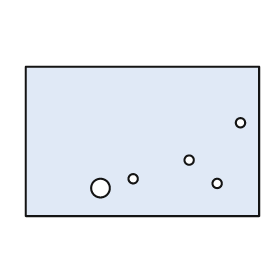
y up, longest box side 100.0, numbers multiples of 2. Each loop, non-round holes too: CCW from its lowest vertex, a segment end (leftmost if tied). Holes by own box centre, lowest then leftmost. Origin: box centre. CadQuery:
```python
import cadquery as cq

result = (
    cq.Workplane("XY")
    .moveTo(-50.0, -32.0)
    .lineTo(50.0, -32.0)
    .lineTo(50.0, 32.0)
    .lineTo(-50.0, 32.0)
    .close()
    .moveTo(-18.0, -20.0)
    .circle(4.0)
    .moveTo(32.0, -18.0)
    .circle(2.0)
    .moveTo(-4.0, -16.0)
    .circle(2.0)
    .moveTo(20.0, -8.0)
    .circle(2.0)
    .moveTo(42.0, 8.0)
    .circle(2.0)
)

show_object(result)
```